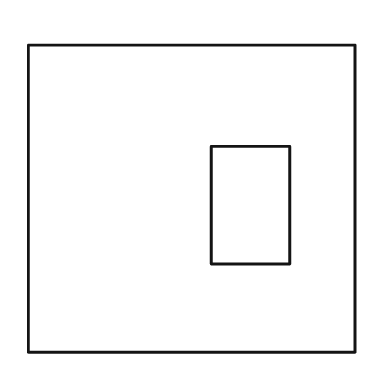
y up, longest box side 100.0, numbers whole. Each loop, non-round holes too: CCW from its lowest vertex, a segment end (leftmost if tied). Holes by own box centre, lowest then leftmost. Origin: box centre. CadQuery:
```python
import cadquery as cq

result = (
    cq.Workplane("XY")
    .moveTo(-50.0, -47.0)
    .lineTo(50.0, -47.0)
    .lineTo(50.0, 47.0)
    .lineTo(-50.0, 47.0)
    .close()
    .moveTo(6.0, -20.0)
    .lineTo(30.0, -20.0)
    .lineTo(30.0, 16.0)
    .lineTo(6.0, 16.0)
    .close()
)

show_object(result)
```